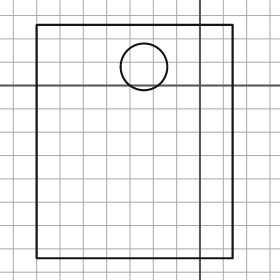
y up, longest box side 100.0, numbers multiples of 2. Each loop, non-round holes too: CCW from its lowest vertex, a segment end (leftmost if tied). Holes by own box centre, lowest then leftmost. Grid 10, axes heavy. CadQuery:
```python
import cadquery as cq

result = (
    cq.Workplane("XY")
    .moveTo(-70.0, -74.0)
    .lineTo(14.0, -74.0)
    .lineTo(14.0, 26.0)
    .lineTo(-70.0, 26.0)
    .close()
    .moveTo(-24.0, 8.0)
    .circle(10.0)
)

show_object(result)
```